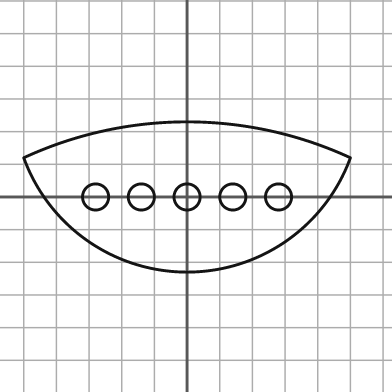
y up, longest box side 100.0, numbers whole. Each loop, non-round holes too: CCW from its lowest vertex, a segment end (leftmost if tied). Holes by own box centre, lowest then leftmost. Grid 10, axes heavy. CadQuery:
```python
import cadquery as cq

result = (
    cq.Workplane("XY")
    .moveTo(-50.0, 12.0)
    .threePointArc((0.0, -23.0), (50.0, 12.0))
    .threePointArc((0.0, 23.0), (-50.0, 12.0))
    .close()
    .moveTo(-28.0, 0.0)
    .circle(4.0)
    .moveTo(-14.0, 0.0)
    .circle(4.0)
    .moveTo(0.0, 0.0)
    .circle(4.0)
    .moveTo(14.0, 0.0)
    .circle(4.0)
    .moveTo(28.0, 0.0)
    .circle(4.0)
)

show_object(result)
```